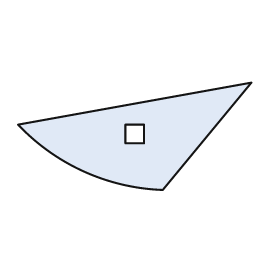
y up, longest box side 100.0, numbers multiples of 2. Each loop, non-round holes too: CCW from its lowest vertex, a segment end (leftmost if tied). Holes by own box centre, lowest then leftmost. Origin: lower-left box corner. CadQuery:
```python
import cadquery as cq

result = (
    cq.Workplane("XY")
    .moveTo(62.0, 0.0)
    .lineTo(100.0, 46.0)
    .lineTo(0.0, 28.0)
    .threePointArc((28.0, 8.0), (62.0, 0.0))
    .close()
    .moveTo(46.0, 20.0)
    .lineTo(54.0, 20.0)
    .lineTo(54.0, 28.0)
    .lineTo(46.0, 28.0)
    .close()
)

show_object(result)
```